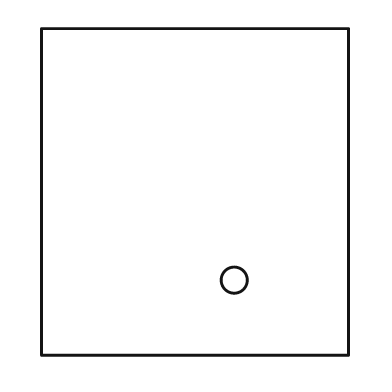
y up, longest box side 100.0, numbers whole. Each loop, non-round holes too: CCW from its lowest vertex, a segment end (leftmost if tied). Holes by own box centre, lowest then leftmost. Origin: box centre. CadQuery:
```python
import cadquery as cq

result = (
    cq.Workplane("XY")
    .moveTo(-47.0, -50.0)
    .lineTo(47.0, -50.0)
    .lineTo(47.0, 50.0)
    .lineTo(-47.0, 50.0)
    .close()
    .moveTo(12.0, -27.0)
    .circle(4.0)
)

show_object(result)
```